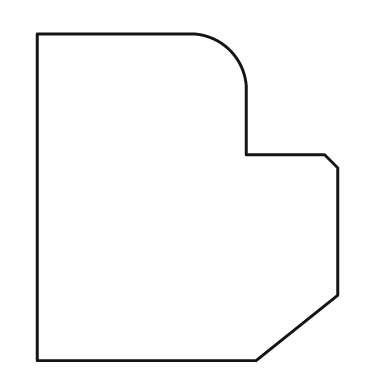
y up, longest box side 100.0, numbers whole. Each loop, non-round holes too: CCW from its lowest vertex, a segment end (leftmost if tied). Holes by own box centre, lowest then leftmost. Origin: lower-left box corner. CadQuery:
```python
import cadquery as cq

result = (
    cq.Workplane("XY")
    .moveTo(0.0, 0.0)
    .lineTo(67.0, 0.0)
    .lineTo(92.0, 20.0)
    .lineTo(92.0, 59.0)
    .lineTo(88.0, 63.0)
    .lineTo(64.0, 63.0)
    .lineTo(64.0, 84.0)
    .threePointArc((59.0, 95.0), (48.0, 100.0))
    .lineTo(0.0, 100.0)
    .close()
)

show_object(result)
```